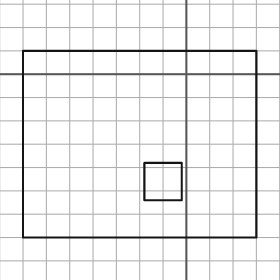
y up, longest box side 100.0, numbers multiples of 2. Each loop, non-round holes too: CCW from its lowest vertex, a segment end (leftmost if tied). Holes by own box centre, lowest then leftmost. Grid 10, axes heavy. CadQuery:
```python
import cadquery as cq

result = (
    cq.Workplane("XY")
    .moveTo(-70.0, -70.0)
    .lineTo(30.0, -70.0)
    .lineTo(30.0, 10.0)
    .lineTo(-70.0, 10.0)
    .close()
    .moveTo(-18.0, -54.0)
    .lineTo(-2.0, -54.0)
    .lineTo(-2.0, -38.0)
    .lineTo(-18.0, -38.0)
    .close()
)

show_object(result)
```